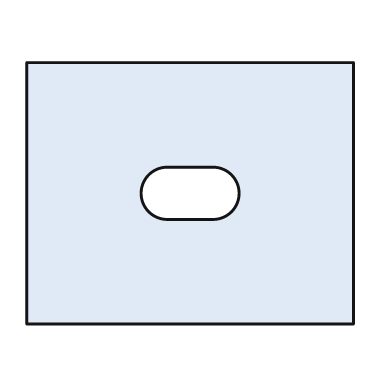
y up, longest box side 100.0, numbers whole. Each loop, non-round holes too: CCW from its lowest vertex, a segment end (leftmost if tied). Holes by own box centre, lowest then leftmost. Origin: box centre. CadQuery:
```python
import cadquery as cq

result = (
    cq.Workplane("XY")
    .moveTo(-50.0, -40.0)
    .lineTo(50.0, -40.0)
    .lineTo(50.0, 40.0)
    .lineTo(-50.0, 40.0)
    .close()
    .moveTo(-7.0, -8.0)
    .lineTo(7.0, -8.0)
    .threePointArc((15.0, 0.0), (7.0, 8.0))
    .lineTo(-7.0, 8.0)
    .threePointArc((-15.0, 0.0), (-7.0, -8.0))
    .close()
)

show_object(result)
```